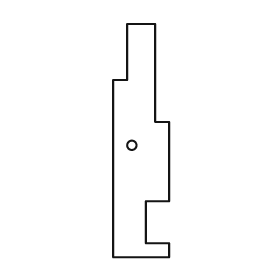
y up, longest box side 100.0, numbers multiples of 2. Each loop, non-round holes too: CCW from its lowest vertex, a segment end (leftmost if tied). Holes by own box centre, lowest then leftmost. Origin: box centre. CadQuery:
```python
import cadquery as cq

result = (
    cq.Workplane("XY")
    .moveTo(-12.0, -50.0)
    .lineTo(12.0, -50.0)
    .lineTo(12.0, -44.0)
    .lineTo(2.0, -44.0)
    .lineTo(2.0, -26.0)
    .lineTo(12.0, -26.0)
    .lineTo(12.0, 8.0)
    .lineTo(6.0, 8.0)
    .lineTo(6.0, 50.0)
    .lineTo(-6.0, 50.0)
    .lineTo(-6.0, 26.0)
    .lineTo(-12.0, 26.0)
    .close()
    .moveTo(-4.0, -2.0)
    .circle(2.0)
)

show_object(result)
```